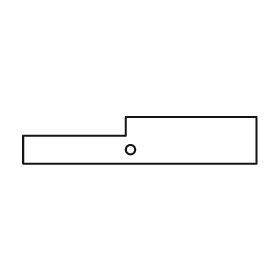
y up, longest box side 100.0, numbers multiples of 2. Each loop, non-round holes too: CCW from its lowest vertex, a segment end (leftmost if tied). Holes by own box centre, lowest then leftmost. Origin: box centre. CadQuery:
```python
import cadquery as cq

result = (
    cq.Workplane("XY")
    .moveTo(-50.0, -10.0)
    .lineTo(50.0, -10.0)
    .lineTo(50.0, 10.0)
    .lineTo(-6.0, 10.0)
    .lineTo(-6.0, 2.0)
    .lineTo(-50.0, 2.0)
    .close()
    .moveTo(-4.0, -4.0)
    .circle(2.0)
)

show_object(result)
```